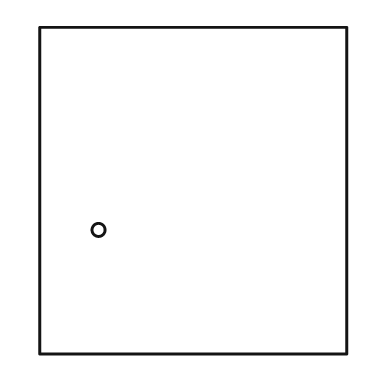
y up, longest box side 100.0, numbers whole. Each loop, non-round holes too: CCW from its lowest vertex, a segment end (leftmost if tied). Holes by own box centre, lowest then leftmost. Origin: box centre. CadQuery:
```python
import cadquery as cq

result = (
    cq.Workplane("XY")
    .moveTo(-47.0, -50.0)
    .lineTo(47.0, -50.0)
    .lineTo(47.0, 50.0)
    .lineTo(-47.0, 50.0)
    .close()
    .moveTo(-29.0, -12.0)
    .circle(2.0)
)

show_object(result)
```